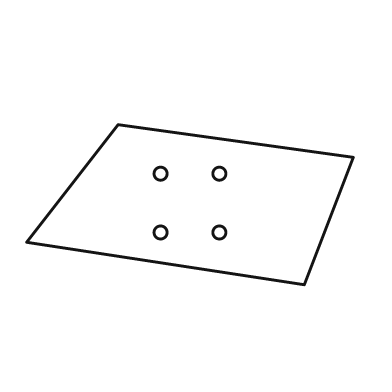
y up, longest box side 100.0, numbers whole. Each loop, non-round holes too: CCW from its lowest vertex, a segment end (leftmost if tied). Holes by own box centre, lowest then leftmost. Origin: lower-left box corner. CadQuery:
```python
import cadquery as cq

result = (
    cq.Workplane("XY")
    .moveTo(85.0, 0.0)
    .lineTo(100.0, 39.0)
    .lineTo(28.0, 49.0)
    .lineTo(0.0, 13.0)
    .close()
    .moveTo(41.0, 16.0)
    .circle(2.0)
    .moveTo(59.0, 16.0)
    .circle(2.0)
    .moveTo(41.0, 34.0)
    .circle(2.0)
    .moveTo(59.0, 34.0)
    .circle(2.0)
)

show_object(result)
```